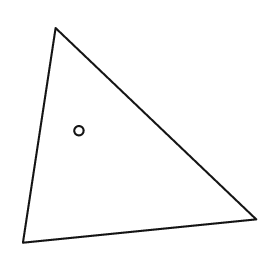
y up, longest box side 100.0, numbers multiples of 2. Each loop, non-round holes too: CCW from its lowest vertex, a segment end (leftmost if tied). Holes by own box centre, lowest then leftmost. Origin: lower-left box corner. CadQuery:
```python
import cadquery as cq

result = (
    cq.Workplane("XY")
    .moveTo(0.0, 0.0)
    .lineTo(100.0, 10.0)
    .lineTo(14.0, 92.0)
    .close()
    .moveTo(24.0, 48.0)
    .circle(2.0)
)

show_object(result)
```